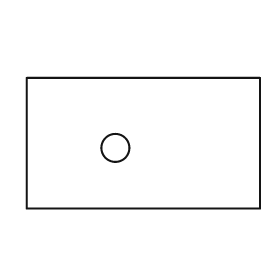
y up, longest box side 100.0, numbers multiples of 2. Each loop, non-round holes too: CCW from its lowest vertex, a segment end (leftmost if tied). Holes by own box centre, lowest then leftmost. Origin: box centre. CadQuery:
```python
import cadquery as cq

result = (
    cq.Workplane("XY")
    .moveTo(-50.0, -28.0)
    .lineTo(50.0, -28.0)
    .lineTo(50.0, 28.0)
    .lineTo(-50.0, 28.0)
    .close()
    .moveTo(-12.0, -2.0)
    .circle(6.0)
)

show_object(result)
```